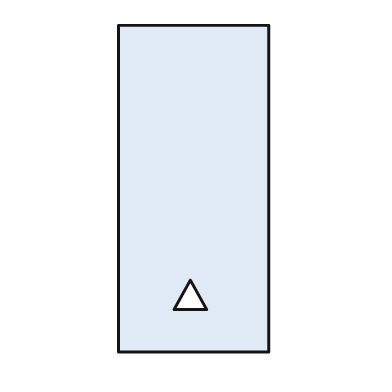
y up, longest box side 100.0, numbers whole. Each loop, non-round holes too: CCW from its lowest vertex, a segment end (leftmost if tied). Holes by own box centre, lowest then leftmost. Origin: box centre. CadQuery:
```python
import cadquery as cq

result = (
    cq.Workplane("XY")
    .moveTo(-23.0, -50.0)
    .lineTo(23.0, -50.0)
    .lineTo(23.0, 50.0)
    .lineTo(-23.0, 50.0)
    .close()
    .moveTo(-6.0, -37.0)
    .lineTo(4.0, -37.0)
    .lineTo(-1.0, -28.0)
    .close()
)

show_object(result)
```